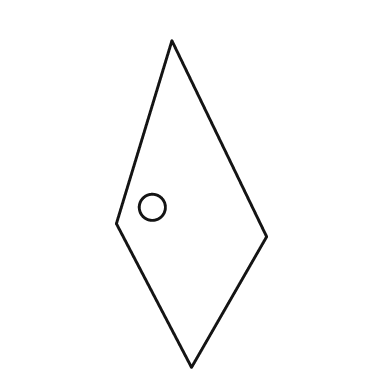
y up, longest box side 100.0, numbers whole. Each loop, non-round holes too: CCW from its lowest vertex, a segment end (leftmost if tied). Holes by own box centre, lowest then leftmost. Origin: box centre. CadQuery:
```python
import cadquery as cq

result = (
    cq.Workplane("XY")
    .moveTo(0.0, -50.0)
    .lineTo(23.0, -10.0)
    .lineTo(-6.0, 50.0)
    .lineTo(-23.0, -6.0)
    .close()
    .moveTo(-12.0, -1.0)
    .circle(4.0)
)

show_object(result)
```